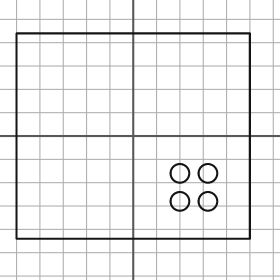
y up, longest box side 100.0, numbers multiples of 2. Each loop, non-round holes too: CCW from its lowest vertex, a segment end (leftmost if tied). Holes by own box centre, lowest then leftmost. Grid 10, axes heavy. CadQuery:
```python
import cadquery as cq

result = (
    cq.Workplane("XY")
    .moveTo(-50.0, -44.0)
    .lineTo(50.0, -44.0)
    .lineTo(50.0, 44.0)
    .lineTo(-50.0, 44.0)
    .close()
    .moveTo(20.0, -28.0)
    .circle(4.0)
    .moveTo(32.0, -28.0)
    .circle(4.0)
    .moveTo(20.0, -16.0)
    .circle(4.0)
    .moveTo(32.0, -16.0)
    .circle(4.0)
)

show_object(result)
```